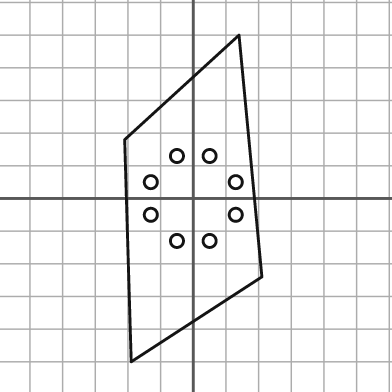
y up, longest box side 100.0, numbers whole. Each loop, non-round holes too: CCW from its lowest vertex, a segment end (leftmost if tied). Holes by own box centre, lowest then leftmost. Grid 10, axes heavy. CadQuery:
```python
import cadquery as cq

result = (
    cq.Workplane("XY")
    .moveTo(-19.0, -50.0)
    .lineTo(21.0, -24.0)
    .lineTo(14.0, 50.0)
    .lineTo(-21.0, 18.0)
    .close()
    .moveTo(-5.0, -13.0)
    .circle(2.0)
    .moveTo(5.0, -13.0)
    .circle(2.0)
    .moveTo(-13.0, -5.0)
    .circle(2.0)
    .moveTo(13.0, -5.0)
    .circle(2.0)
    .moveTo(-13.0, 5.0)
    .circle(2.0)
    .moveTo(13.0, 5.0)
    .circle(2.0)
    .moveTo(-5.0, 13.0)
    .circle(2.0)
    .moveTo(5.0, 13.0)
    .circle(2.0)
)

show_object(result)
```